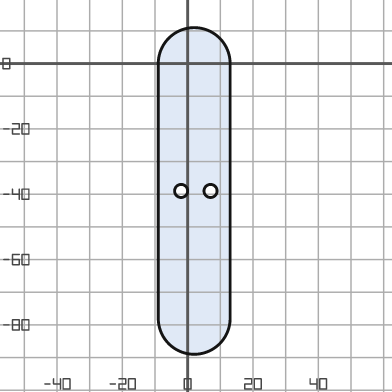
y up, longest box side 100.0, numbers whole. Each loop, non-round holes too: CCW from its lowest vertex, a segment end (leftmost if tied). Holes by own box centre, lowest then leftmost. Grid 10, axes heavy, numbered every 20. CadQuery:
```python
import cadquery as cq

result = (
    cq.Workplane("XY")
    .moveTo(-9.0, -78.0)
    .threePointArc((2.0, -89.0), (13.0, -78.0))
    .lineTo(13.0, 0.0)
    .threePointArc((2.0, 11.0), (-9.0, 0.0))
    .close()
    .moveTo(-2.0, -39.0)
    .circle(2.0)
    .moveTo(7.0, -39.0)
    .circle(2.0)
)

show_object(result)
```